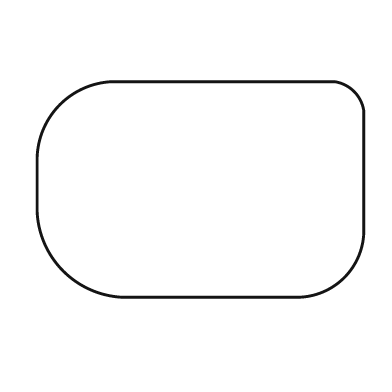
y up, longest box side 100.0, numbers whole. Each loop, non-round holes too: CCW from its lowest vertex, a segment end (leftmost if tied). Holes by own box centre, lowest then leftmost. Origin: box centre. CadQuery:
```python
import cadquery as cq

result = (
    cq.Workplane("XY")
    .moveTo(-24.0, -33.0)
    .lineTo(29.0, -33.0)
    .threePointArc((44.0, -27.0), (50.0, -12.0))
    .lineTo(50.0, 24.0)
    .threePointArc((47.0, 30.0), (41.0, 33.0))
    .lineTo(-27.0, 33.0)
    .threePointArc((-43.0, 26.0), (-50.0, 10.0))
    .lineTo(-50.0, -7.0)
    .threePointArc((-42.0, -25.0), (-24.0, -33.0))
    .close()
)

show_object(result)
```